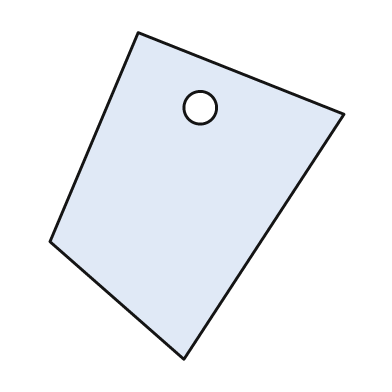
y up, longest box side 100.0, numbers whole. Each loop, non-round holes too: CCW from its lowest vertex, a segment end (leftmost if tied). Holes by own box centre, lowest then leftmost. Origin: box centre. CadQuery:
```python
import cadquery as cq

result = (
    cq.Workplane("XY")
    .moveTo(-4.0, -50.0)
    .lineTo(45.0, 25.0)
    .lineTo(-18.0, 50.0)
    .lineTo(-45.0, -14.0)
    .close()
    .moveTo(1.0, 27.0)
    .circle(5.0)
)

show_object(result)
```